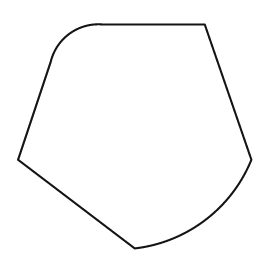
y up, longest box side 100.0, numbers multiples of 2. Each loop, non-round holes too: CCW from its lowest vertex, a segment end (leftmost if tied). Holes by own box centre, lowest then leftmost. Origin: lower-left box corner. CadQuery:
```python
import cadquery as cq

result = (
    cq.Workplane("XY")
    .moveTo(50.0, 0.0)
    .threePointArc((80.0, 12.0), (100.0, 38.0))
    .lineTo(80.0, 96.0)
    .lineTo(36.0, 96.0)
    .threePointArc((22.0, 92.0), (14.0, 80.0))
    .lineTo(0.0, 38.0)
    .close()
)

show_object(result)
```